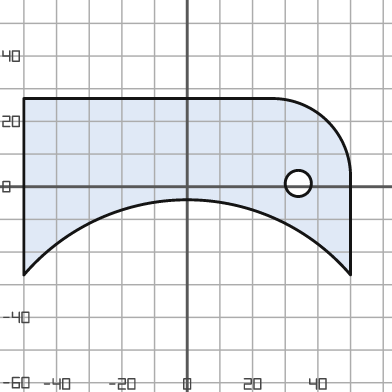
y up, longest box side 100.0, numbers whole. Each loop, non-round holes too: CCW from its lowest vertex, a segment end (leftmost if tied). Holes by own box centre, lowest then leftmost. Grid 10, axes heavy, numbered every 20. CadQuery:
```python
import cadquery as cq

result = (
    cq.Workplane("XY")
    .moveTo(-50.0, -27.0)
    .threePointArc((0.0, -4.0), (50.0, -27.0))
    .lineTo(50.0, 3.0)
    .threePointArc((43.0, 20.0), (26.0, 27.0))
    .lineTo(-50.0, 27.0)
    .close()
    .moveTo(34.0, 1.0)
    .circle(4.0)
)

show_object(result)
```